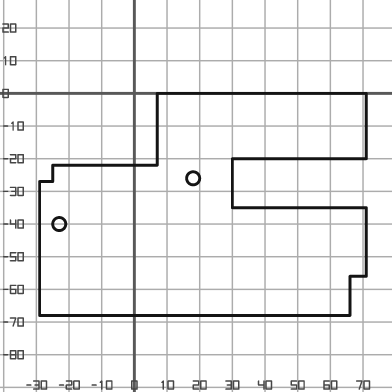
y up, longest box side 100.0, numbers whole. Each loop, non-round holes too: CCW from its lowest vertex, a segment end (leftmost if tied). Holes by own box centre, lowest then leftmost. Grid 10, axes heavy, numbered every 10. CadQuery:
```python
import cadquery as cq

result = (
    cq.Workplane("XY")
    .moveTo(-29.0, -68.0)
    .lineTo(66.0, -68.0)
    .lineTo(66.0, -56.0)
    .lineTo(71.0, -56.0)
    .lineTo(71.0, -35.0)
    .lineTo(30.0, -35.0)
    .lineTo(30.0, -20.0)
    .lineTo(71.0, -20.0)
    .lineTo(71.0, 0.0)
    .lineTo(7.0, 0.0)
    .lineTo(7.0, -22.0)
    .lineTo(-25.0, -22.0)
    .lineTo(-25.0, -27.0)
    .lineTo(-29.0, -27.0)
    .close()
    .moveTo(-23.0, -40.0)
    .circle(2.0)
    .moveTo(18.0, -26.0)
    .circle(2.0)
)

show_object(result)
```